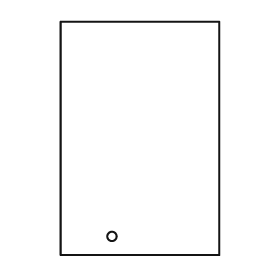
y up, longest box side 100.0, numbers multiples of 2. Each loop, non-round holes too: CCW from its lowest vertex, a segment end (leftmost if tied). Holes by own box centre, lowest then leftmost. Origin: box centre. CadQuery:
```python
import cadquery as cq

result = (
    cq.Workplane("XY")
    .moveTo(-34.0, -50.0)
    .lineTo(34.0, -50.0)
    .lineTo(34.0, 50.0)
    .lineTo(-34.0, 50.0)
    .close()
    .moveTo(-12.0, -42.0)
    .circle(2.0)
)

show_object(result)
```